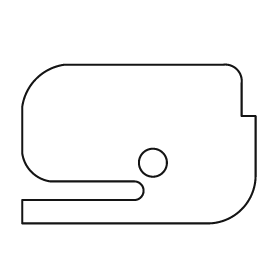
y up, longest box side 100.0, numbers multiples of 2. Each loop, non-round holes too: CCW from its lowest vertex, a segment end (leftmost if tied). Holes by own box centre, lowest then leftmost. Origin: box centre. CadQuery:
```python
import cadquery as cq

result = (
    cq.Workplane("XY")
    .moveTo(-50.0, -34.0)
    .lineTo(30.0, -34.0)
    .threePointArc((44.0, -28.0), (50.0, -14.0))
    .lineTo(50.0, 12.0)
    .lineTo(44.0, 12.0)
    .lineTo(44.0, 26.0)
    .threePointArc((42.0, 32.0), (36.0, 34.0))
    .lineTo(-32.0, 34.0)
    .threePointArc((-44.0, 28.0), (-50.0, 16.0))
    .lineTo(-50.0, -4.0)
    .threePointArc((-46.0, -12.0), (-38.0, -16.0))
    .lineTo(-2.0, -16.0)
    .threePointArc((2.0, -20.0), (-2.0, -24.0))
    .lineTo(-50.0, -24.0)
    .close()
    .moveTo(6.0, -8.0)
    .circle(6.0)
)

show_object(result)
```